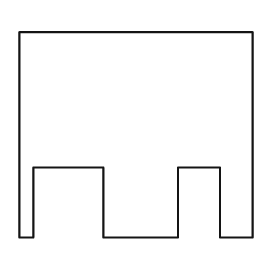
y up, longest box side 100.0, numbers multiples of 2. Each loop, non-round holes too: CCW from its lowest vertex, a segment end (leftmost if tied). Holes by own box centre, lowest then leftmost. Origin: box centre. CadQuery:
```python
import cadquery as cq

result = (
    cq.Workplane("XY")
    .moveTo(-50.0, -44.0)
    .lineTo(-44.0, -44.0)
    .lineTo(-44.0, -14.0)
    .lineTo(-14.0, -14.0)
    .lineTo(-14.0, -44.0)
    .lineTo(18.0, -44.0)
    .lineTo(18.0, -14.0)
    .lineTo(36.0, -14.0)
    .lineTo(36.0, -44.0)
    .lineTo(50.0, -44.0)
    .lineTo(50.0, 44.0)
    .lineTo(-50.0, 44.0)
    .close()
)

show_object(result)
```